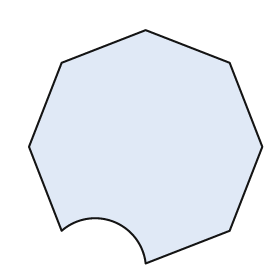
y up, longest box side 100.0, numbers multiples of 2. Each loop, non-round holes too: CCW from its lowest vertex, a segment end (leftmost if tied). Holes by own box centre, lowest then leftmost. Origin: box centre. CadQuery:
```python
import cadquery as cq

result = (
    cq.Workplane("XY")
    .moveTo(0.0, -50.0)
    .lineTo(36.0, -36.0)
    .lineTo(50.0, 0.0)
    .lineTo(36.0, 36.0)
    .lineTo(0.0, 50.0)
    .lineTo(-36.0, 36.0)
    .lineTo(-50.0, 0.0)
    .lineTo(-36.0, -36.0)
    .threePointArc((-14.0, -32.0), (0.0, -50.0))
    .close()
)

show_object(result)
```